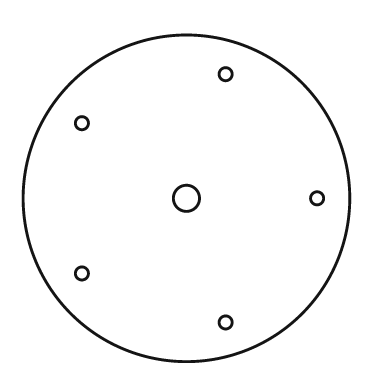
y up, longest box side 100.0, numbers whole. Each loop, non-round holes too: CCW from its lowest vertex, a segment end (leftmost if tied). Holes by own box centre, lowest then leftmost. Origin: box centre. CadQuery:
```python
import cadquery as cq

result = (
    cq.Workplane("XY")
    .moveTo(0.0, 0.0)
    .circle(50.0)
    .moveTo(12.0, -38.0)
    .circle(2.0)
    .moveTo(-32.0, -23.0)
    .circle(2.0)
    .moveTo(0.0, 0.0)
    .circle(4.0)
    .moveTo(40.0, 0.0)
    .circle(2.0)
    .moveTo(-32.0, 23.0)
    .circle(2.0)
    .moveTo(12.0, 38.0)
    .circle(2.0)
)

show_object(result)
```